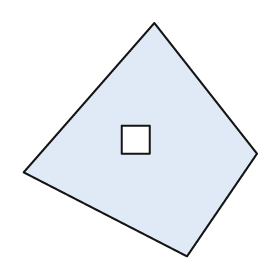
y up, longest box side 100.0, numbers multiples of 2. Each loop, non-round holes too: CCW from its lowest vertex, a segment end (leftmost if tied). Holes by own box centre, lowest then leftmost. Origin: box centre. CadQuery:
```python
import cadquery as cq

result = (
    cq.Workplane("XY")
    .moveTo(20.0, -50.0)
    .lineTo(50.0, -6.0)
    .lineTo(6.0, 50.0)
    .lineTo(-50.0, -14.0)
    .close()
    .moveTo(-8.0, -6.0)
    .lineTo(4.0, -6.0)
    .lineTo(4.0, 6.0)
    .lineTo(-8.0, 6.0)
    .close()
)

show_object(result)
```